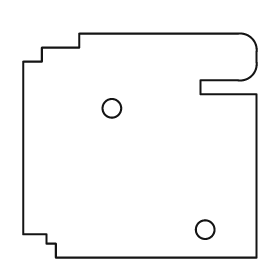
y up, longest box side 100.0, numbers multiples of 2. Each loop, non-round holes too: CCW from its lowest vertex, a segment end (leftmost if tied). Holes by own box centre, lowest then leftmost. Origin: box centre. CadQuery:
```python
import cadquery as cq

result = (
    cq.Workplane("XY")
    .moveTo(-36.0, -48.0)
    .lineTo(50.0, -48.0)
    .lineTo(50.0, 22.0)
    .lineTo(26.0, 22.0)
    .lineTo(26.0, 28.0)
    .lineTo(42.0, 28.0)
    .threePointArc((48.0, 30.0), (50.0, 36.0))
    .lineTo(50.0, 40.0)
    .threePointArc((48.0, 46.0), (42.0, 48.0))
    .lineTo(-26.0, 48.0)
    .lineTo(-26.0, 42.0)
    .lineTo(-42.0, 42.0)
    .lineTo(-42.0, 36.0)
    .lineTo(-50.0, 36.0)
    .lineTo(-50.0, -38.0)
    .lineTo(-40.0, -38.0)
    .lineTo(-40.0, -42.0)
    .lineTo(-36.0, -42.0)
    .close()
    .moveTo(28.0, -36.0)
    .circle(4.0)
    .moveTo(-12.0, 16.0)
    .circle(4.0)
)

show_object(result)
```